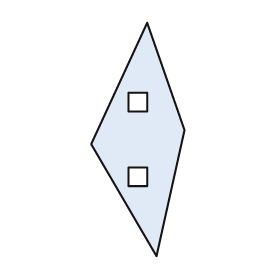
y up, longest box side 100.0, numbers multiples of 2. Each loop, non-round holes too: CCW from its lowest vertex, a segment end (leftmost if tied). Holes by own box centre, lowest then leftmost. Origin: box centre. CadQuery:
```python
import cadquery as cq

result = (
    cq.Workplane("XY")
    .moveTo(8.0, -50.0)
    .lineTo(20.0, 4.0)
    .lineTo(4.0, 50.0)
    .lineTo(-20.0, -2.0)
    .close()
    .moveTo(-4.0, -20.0)
    .lineTo(4.0, -20.0)
    .lineTo(4.0, -12.0)
    .lineTo(-4.0, -12.0)
    .close()
    .moveTo(-4.0, 12.0)
    .lineTo(4.0, 12.0)
    .lineTo(4.0, 20.0)
    .lineTo(-4.0, 20.0)
    .close()
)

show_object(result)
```